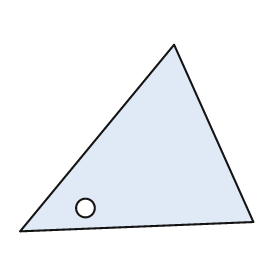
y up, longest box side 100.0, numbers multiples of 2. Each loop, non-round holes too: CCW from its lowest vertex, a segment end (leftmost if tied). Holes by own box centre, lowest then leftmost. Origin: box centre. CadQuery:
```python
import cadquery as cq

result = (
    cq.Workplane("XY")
    .moveTo(-50.0, -40.0)
    .lineTo(50.0, -36.0)
    .lineTo(16.0, 40.0)
    .close()
    .moveTo(-22.0, -30.0)
    .circle(4.0)
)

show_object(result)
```